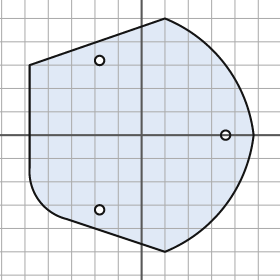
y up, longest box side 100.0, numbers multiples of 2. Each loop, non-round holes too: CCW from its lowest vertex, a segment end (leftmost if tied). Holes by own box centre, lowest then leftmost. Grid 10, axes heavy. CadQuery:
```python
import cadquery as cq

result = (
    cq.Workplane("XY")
    .moveTo(10.0, -50.0)
    .threePointArc((36.0, -30.0), (48.0, 0.0))
    .threePointArc((36.0, 30.0), (10.0, 50.0))
    .lineTo(-48.0, 30.0)
    .lineTo(-48.0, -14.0)
    .threePointArc((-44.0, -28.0), (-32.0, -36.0))
    .close()
    .moveTo(-18.0, -32.0)
    .circle(2.0)
    .moveTo(36.0, 0.0)
    .circle(2.0)
    .moveTo(-18.0, 32.0)
    .circle(2.0)
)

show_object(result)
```